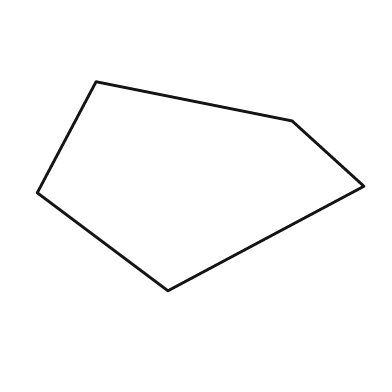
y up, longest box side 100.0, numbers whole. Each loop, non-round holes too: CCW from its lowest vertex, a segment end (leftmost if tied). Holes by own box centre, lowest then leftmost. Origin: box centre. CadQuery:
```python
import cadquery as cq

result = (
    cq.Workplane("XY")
    .moveTo(-10.0, -32.0)
    .lineTo(50.0, 0.0)
    .lineTo(28.0, 20.0)
    .lineTo(-32.0, 32.0)
    .lineTo(-50.0, -2.0)
    .close()
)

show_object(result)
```